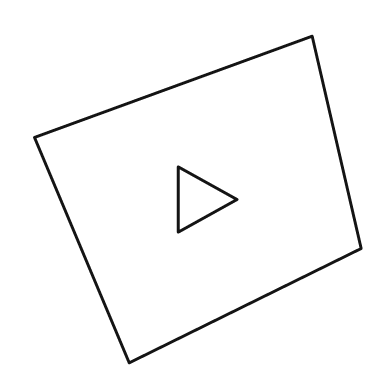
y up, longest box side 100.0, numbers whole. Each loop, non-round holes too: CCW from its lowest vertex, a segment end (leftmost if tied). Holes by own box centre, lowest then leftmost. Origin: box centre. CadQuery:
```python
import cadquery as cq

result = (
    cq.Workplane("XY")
    .moveTo(-21.0, -50.0)
    .lineTo(50.0, -15.0)
    .lineTo(35.0, 50.0)
    .lineTo(-50.0, 19.0)
    .close()
    .moveTo(-6.0, -10.0)
    .lineTo(12.0, 0.0)
    .lineTo(-6.0, 10.0)
    .close()
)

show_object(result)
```